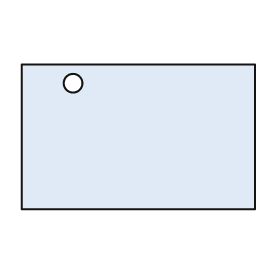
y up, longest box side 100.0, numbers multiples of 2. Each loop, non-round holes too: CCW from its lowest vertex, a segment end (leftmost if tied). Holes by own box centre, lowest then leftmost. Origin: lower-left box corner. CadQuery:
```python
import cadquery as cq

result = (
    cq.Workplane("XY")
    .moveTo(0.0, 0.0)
    .lineTo(100.0, 0.0)
    .lineTo(100.0, 62.0)
    .lineTo(0.0, 62.0)
    .close()
    .moveTo(22.0, 54.0)
    .circle(4.0)
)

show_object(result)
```